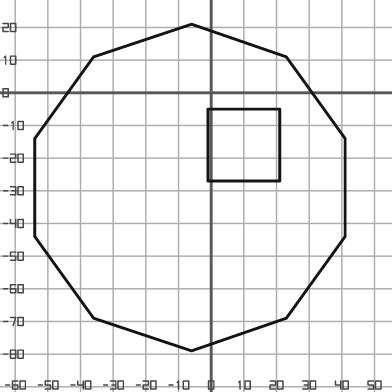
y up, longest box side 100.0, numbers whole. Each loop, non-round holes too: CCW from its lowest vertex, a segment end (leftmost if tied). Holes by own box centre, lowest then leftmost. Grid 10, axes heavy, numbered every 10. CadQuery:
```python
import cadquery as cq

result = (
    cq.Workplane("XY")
    .moveTo(-6.0, -79.0)
    .lineTo(23.0, -69.0)
    .lineTo(41.0, -44.0)
    .lineTo(41.0, -14.0)
    .lineTo(23.0, 11.0)
    .lineTo(-6.0, 21.0)
    .lineTo(-36.0, 11.0)
    .lineTo(-54.0, -14.0)
    .lineTo(-54.0, -44.0)
    .lineTo(-36.0, -69.0)
    .close()
    .moveTo(-1.0, -27.0)
    .lineTo(21.0, -27.0)
    .lineTo(21.0, -5.0)
    .lineTo(-1.0, -5.0)
    .close()
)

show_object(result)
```